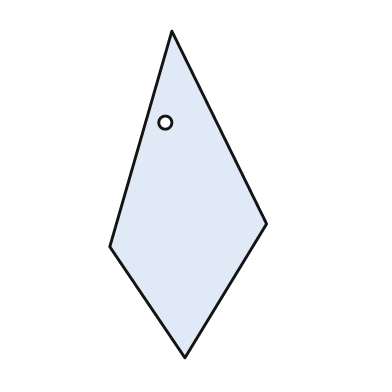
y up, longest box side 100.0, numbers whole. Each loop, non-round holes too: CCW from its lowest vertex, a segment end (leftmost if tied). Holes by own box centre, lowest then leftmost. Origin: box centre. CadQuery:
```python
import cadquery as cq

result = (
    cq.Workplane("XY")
    .moveTo(-1.0, -50.0)
    .lineTo(24.0, -9.0)
    .lineTo(-5.0, 50.0)
    .lineTo(-24.0, -16.0)
    .close()
    .moveTo(-7.0, 22.0)
    .circle(2.0)
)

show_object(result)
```